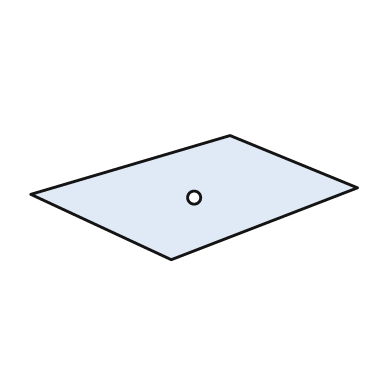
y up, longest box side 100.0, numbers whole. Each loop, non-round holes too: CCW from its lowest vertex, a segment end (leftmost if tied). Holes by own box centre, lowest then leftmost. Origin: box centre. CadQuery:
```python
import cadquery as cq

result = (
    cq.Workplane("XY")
    .moveTo(-7.0, -19.0)
    .lineTo(50.0, 3.0)
    .lineTo(11.0, 19.0)
    .lineTo(-50.0, 1.0)
    .close()
    .moveTo(0.0, 0.0)
    .circle(2.0)
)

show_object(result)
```